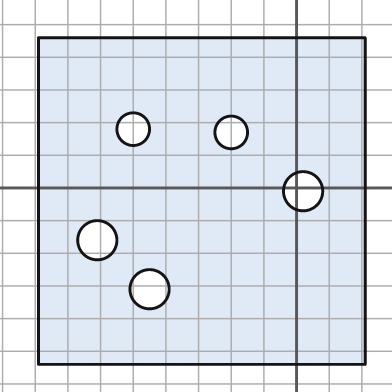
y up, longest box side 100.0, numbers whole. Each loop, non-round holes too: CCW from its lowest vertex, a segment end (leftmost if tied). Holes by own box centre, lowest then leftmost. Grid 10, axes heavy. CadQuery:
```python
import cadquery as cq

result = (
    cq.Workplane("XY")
    .moveTo(-79.0, -54.0)
    .lineTo(21.0, -54.0)
    .lineTo(21.0, 46.0)
    .lineTo(-79.0, 46.0)
    .close()
    .moveTo(-45.0, -31.0)
    .circle(6.0)
    .moveTo(-61.0, -16.0)
    .circle(6.0)
    .moveTo(2.0, -1.0)
    .circle(6.0)
    .moveTo(-20.0, 17.0)
    .circle(5.0)
    .moveTo(-50.0, 18.0)
    .circle(5.0)
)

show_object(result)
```